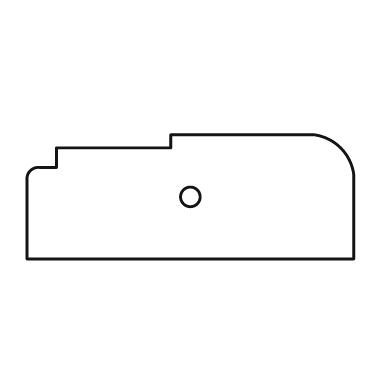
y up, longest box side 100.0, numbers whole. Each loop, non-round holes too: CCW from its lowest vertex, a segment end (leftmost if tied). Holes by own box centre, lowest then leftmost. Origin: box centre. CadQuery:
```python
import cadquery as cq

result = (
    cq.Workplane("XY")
    .moveTo(-50.0, -19.0)
    .lineTo(50.0, -19.0)
    .lineTo(50.0, 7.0)
    .threePointArc((46.0, 15.0), (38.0, 19.0))
    .lineTo(-6.0, 19.0)
    .lineTo(-6.0, 15.0)
    .lineTo(-41.0, 15.0)
    .lineTo(-41.0, 9.0)
    .lineTo(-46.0, 9.0)
    .threePointArc((-49.0, 8.0), (-50.0, 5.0))
    .close()
    .moveTo(0.0, 0.0)
    .circle(3.0)
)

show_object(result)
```